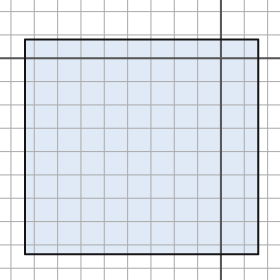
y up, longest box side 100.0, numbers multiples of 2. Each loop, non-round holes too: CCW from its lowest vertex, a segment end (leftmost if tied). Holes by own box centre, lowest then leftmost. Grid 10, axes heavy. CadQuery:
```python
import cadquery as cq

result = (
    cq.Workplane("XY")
    .moveTo(-84.0, -84.0)
    .lineTo(16.0, -84.0)
    .lineTo(16.0, 8.0)
    .lineTo(-84.0, 8.0)
    .close()
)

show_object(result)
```